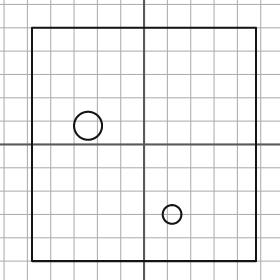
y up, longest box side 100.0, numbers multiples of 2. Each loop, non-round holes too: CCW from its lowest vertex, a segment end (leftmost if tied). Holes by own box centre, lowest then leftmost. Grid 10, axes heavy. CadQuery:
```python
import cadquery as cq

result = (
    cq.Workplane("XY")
    .moveTo(-48.0, -50.0)
    .lineTo(48.0, -50.0)
    .lineTo(48.0, 50.0)
    .lineTo(-48.0, 50.0)
    .close()
    .moveTo(12.0, -30.0)
    .circle(4.0)
    .moveTo(-24.0, 8.0)
    .circle(6.0)
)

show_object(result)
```